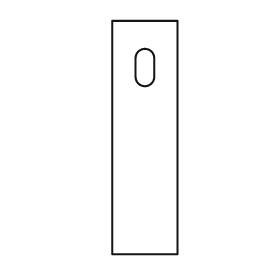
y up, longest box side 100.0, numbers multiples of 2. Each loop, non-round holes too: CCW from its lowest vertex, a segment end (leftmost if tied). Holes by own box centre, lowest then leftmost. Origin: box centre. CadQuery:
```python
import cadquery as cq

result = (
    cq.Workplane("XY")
    .moveTo(-14.0, -50.0)
    .lineTo(14.0, -50.0)
    .lineTo(14.0, 50.0)
    .lineTo(-14.0, 50.0)
    .close()
    .moveTo(-4.0, 26.0)
    .threePointArc((0.0, 22.0), (4.0, 26.0))
    .lineTo(4.0, 34.0)
    .threePointArc((0.0, 38.0), (-4.0, 34.0))
    .close()
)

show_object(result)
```